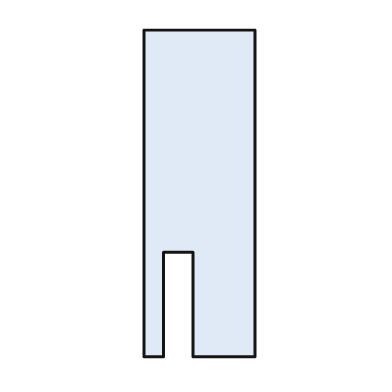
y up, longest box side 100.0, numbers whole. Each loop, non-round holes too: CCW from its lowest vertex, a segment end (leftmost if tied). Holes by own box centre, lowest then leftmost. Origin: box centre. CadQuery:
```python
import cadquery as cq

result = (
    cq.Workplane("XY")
    .moveTo(-17.0, -50.0)
    .lineTo(-11.0, -50.0)
    .lineTo(-11.0, -18.0)
    .lineTo(-2.0, -18.0)
    .lineTo(-2.0, -50.0)
    .lineTo(17.0, -50.0)
    .lineTo(17.0, 50.0)
    .lineTo(-17.0, 50.0)
    .close()
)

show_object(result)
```